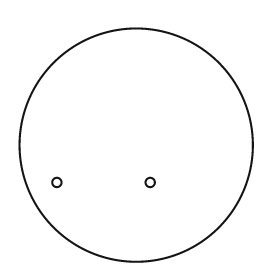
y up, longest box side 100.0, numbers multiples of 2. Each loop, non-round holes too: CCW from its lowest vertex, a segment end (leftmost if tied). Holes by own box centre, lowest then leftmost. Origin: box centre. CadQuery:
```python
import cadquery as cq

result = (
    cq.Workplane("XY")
    .moveTo(0.0, 0.0)
    .circle(50.0)
    .moveTo(-34.0, -16.0)
    .circle(2.0)
    .moveTo(6.0, -16.0)
    .circle(2.0)
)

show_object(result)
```